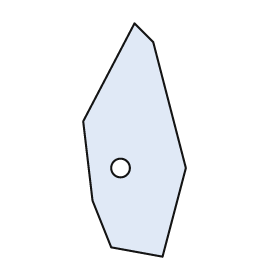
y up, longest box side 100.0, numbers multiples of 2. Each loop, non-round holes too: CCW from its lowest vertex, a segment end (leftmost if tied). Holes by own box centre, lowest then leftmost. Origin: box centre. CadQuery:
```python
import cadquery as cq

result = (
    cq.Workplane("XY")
    .moveTo(12.0, -50.0)
    .lineTo(22.0, -12.0)
    .lineTo(8.0, 42.0)
    .lineTo(0.0, 50.0)
    .lineTo(-22.0, 8.0)
    .lineTo(-18.0, -26.0)
    .lineTo(-10.0, -46.0)
    .close()
    .moveTo(-6.0, -12.0)
    .circle(4.0)
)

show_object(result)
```